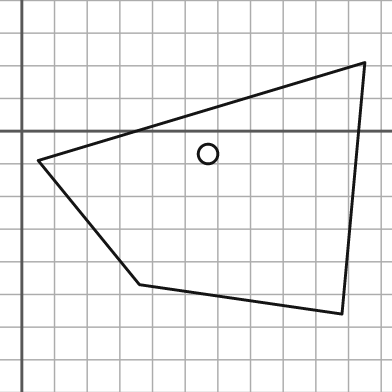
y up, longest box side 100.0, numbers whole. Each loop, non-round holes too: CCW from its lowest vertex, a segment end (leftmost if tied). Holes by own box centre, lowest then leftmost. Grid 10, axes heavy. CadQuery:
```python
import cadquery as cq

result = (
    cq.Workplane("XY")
    .moveTo(98.0, -56.0)
    .lineTo(105.0, 21.0)
    .lineTo(5.0, -9.0)
    .lineTo(36.0, -47.0)
    .close()
    .moveTo(57.0, -7.0)
    .circle(3.0)
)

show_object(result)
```